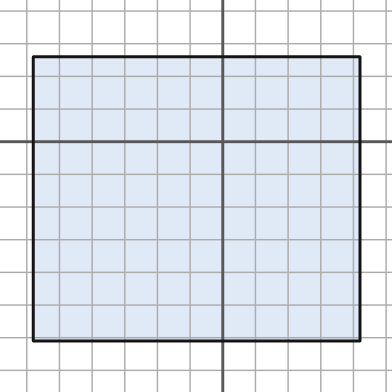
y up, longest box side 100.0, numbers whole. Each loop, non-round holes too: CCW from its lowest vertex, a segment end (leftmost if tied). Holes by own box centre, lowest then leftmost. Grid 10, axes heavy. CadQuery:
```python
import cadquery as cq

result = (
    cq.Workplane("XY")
    .moveTo(-58.0, -61.0)
    .lineTo(42.0, -61.0)
    .lineTo(42.0, 26.0)
    .lineTo(-58.0, 26.0)
    .close()
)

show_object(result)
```